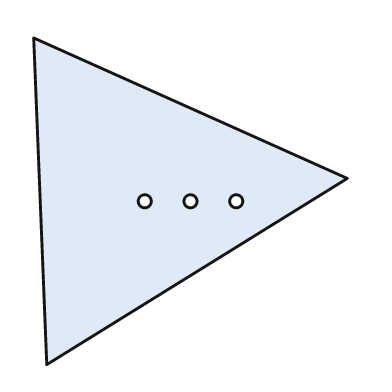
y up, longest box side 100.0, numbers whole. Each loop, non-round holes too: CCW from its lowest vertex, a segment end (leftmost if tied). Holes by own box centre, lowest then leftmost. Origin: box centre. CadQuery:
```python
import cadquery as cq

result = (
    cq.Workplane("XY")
    .moveTo(-44.0, -50.0)
    .lineTo(48.0, 7.0)
    .lineTo(-48.0, 50.0)
    .close()
    .moveTo(-14.0, 0.0)
    .circle(2.0)
    .moveTo(0.0, 0.0)
    .circle(2.0)
    .moveTo(14.0, 0.0)
    .circle(2.0)
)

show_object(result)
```